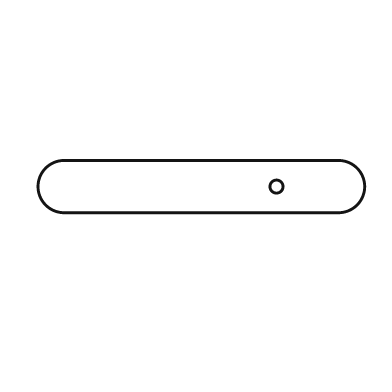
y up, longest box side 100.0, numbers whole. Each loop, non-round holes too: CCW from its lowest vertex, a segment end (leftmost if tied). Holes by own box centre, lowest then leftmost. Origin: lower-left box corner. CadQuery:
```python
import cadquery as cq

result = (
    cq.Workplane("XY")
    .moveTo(8.0, 0.0)
    .lineTo(92.0, 0.0)
    .threePointArc((100.0, 8.0), (92.0, 16.0))
    .lineTo(8.0, 16.0)
    .threePointArc((0.0, 8.0), (8.0, 0.0))
    .close()
    .moveTo(73.0, 8.0)
    .circle(2.0)
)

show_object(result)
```